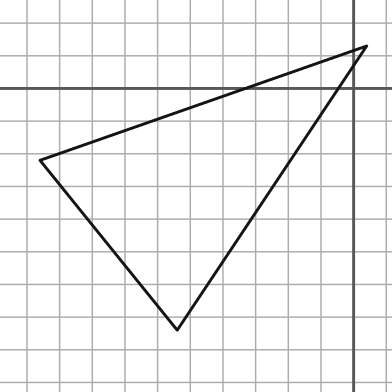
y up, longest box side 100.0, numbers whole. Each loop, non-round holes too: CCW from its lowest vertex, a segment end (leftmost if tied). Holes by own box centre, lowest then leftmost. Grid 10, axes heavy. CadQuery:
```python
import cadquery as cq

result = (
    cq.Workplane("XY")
    .moveTo(-54.0, -74.0)
    .lineTo(4.0, 13.0)
    .lineTo(-96.0, -22.0)
    .close()
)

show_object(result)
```